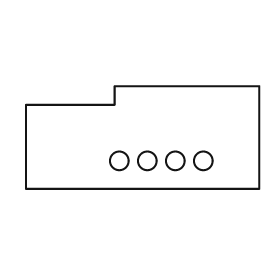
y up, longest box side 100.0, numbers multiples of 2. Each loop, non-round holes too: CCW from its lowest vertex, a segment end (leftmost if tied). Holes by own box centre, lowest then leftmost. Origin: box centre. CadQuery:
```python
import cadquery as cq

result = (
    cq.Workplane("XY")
    .moveTo(-50.0, -22.0)
    .lineTo(50.0, -22.0)
    .lineTo(50.0, 22.0)
    .lineTo(-12.0, 22.0)
    .lineTo(-12.0, 14.0)
    .lineTo(-50.0, 14.0)
    .close()
    .moveTo(-10.0, -10.0)
    .circle(4.0)
    .moveTo(2.0, -10.0)
    .circle(4.0)
    .moveTo(14.0, -10.0)
    .circle(4.0)
    .moveTo(26.0, -10.0)
    .circle(4.0)
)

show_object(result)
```